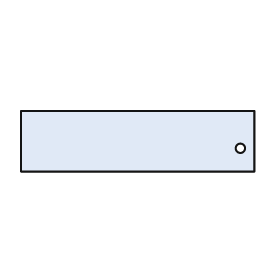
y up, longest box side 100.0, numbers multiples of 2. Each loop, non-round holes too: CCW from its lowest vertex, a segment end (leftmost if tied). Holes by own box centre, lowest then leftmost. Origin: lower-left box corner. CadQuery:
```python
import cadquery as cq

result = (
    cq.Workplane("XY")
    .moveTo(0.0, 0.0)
    .lineTo(100.0, 0.0)
    .lineTo(100.0, 26.0)
    .lineTo(0.0, 26.0)
    .close()
    .moveTo(94.0, 10.0)
    .circle(2.0)
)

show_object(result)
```